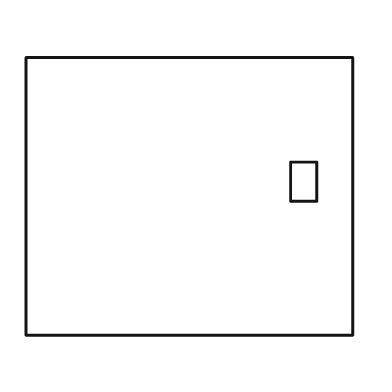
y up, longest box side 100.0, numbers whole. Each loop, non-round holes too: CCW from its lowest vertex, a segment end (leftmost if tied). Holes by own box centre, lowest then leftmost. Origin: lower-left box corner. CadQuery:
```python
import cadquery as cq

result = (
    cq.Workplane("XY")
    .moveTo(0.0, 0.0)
    .lineTo(100.0, 0.0)
    .lineTo(100.0, 85.0)
    .lineTo(0.0, 85.0)
    .close()
    .moveTo(81.0, 41.0)
    .lineTo(89.0, 41.0)
    .lineTo(89.0, 53.0)
    .lineTo(81.0, 53.0)
    .close()
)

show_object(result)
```